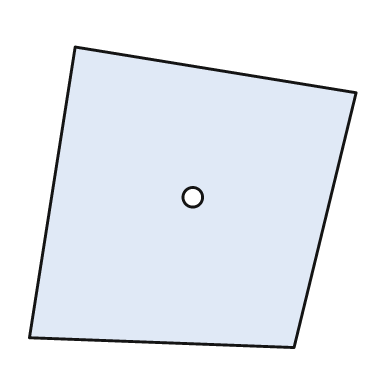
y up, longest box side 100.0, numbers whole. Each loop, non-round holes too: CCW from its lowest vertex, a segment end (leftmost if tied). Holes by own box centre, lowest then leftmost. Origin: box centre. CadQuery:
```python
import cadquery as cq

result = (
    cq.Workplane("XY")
    .moveTo(31.0, -46.0)
    .lineTo(50.0, 32.0)
    .lineTo(-36.0, 46.0)
    .lineTo(-50.0, -43.0)
    .close()
    .moveTo(0.0, 0.0)
    .circle(3.0)
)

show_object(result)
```